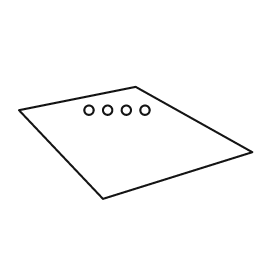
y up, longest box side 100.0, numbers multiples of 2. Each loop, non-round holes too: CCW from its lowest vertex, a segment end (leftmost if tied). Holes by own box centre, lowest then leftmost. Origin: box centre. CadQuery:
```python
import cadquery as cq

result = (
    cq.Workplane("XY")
    .moveTo(-14.0, -24.0)
    .lineTo(50.0, -4.0)
    .lineTo(0.0, 24.0)
    .lineTo(-50.0, 14.0)
    .close()
    .moveTo(-20.0, 14.0)
    .circle(2.0)
    .moveTo(-12.0, 14.0)
    .circle(2.0)
    .moveTo(-4.0, 14.0)
    .circle(2.0)
    .moveTo(4.0, 14.0)
    .circle(2.0)
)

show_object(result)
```